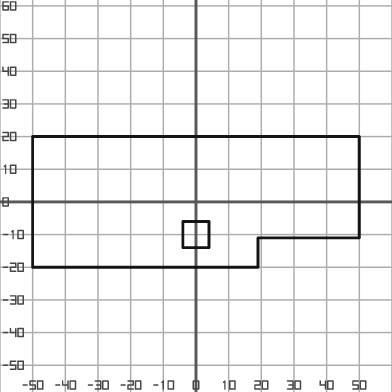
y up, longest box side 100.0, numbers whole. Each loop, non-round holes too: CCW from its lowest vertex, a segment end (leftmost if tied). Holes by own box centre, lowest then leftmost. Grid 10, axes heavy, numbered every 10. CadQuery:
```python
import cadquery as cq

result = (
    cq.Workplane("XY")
    .moveTo(-50.0, -20.0)
    .lineTo(19.0, -20.0)
    .lineTo(19.0, -11.0)
    .lineTo(50.0, -11.0)
    .lineTo(50.0, 20.0)
    .lineTo(-50.0, 20.0)
    .close()
    .moveTo(-4.0, -14.0)
    .lineTo(4.0, -14.0)
    .lineTo(4.0, -6.0)
    .lineTo(-4.0, -6.0)
    .close()
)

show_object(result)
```